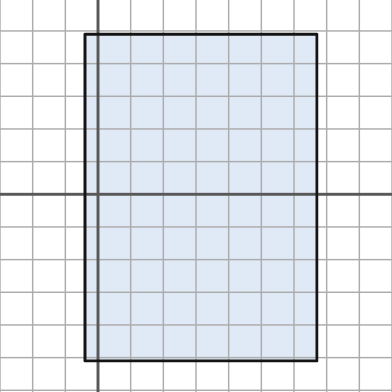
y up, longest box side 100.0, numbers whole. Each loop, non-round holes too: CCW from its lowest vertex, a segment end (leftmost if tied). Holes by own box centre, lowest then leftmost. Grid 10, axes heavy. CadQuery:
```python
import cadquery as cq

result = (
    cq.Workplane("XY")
    .moveTo(-4.0, -51.0)
    .lineTo(67.0, -51.0)
    .lineTo(67.0, 49.0)
    .lineTo(-4.0, 49.0)
    .close()
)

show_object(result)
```